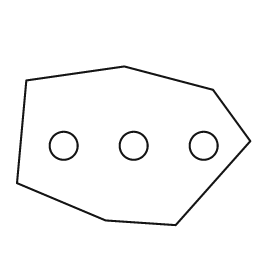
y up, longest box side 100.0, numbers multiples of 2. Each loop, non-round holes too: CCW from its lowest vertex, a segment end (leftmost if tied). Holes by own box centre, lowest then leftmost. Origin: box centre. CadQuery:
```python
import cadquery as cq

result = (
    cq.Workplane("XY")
    .moveTo(18.0, -34.0)
    .lineTo(50.0, 2.0)
    .lineTo(34.0, 24.0)
    .lineTo(-4.0, 34.0)
    .lineTo(-46.0, 28.0)
    .lineTo(-50.0, -16.0)
    .lineTo(-12.0, -32.0)
    .close()
    .moveTo(-30.0, 0.0)
    .circle(6.0)
    .moveTo(0.0, 0.0)
    .circle(6.0)
    .moveTo(30.0, 0.0)
    .circle(6.0)
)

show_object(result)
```